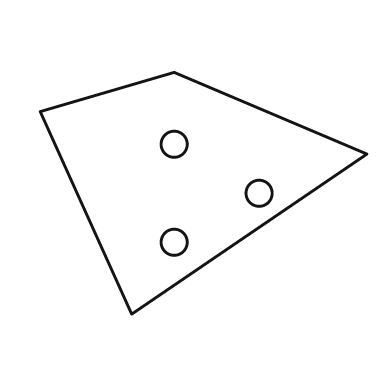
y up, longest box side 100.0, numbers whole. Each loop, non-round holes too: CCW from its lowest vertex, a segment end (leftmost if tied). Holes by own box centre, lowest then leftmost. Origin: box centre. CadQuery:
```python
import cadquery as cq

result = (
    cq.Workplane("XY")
    .moveTo(-22.0, -37.0)
    .lineTo(50.0, 12.0)
    .lineTo(-9.0, 37.0)
    .lineTo(-50.0, 25.0)
    .close()
    .moveTo(-9.0, -15.0)
    .circle(4.0)
    .moveTo(17.0, 0.0)
    .circle(4.0)
    .moveTo(-9.0, 15.0)
    .circle(4.0)
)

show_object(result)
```